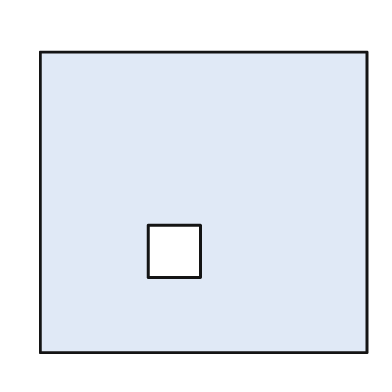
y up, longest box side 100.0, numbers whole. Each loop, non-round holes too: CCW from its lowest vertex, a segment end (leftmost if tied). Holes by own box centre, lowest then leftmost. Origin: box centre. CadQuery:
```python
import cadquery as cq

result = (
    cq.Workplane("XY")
    .moveTo(-50.0, -46.0)
    .lineTo(50.0, -46.0)
    .lineTo(50.0, 46.0)
    .lineTo(-50.0, 46.0)
    .close()
    .moveTo(-17.0, -23.0)
    .lineTo(-1.0, -23.0)
    .lineTo(-1.0, -7.0)
    .lineTo(-17.0, -7.0)
    .close()
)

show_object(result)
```